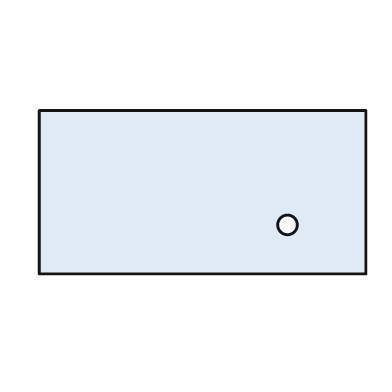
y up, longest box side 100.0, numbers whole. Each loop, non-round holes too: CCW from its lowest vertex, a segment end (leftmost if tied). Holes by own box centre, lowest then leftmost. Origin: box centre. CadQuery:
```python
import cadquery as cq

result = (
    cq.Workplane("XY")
    .moveTo(-50.0, -25.0)
    .lineTo(50.0, -25.0)
    .lineTo(50.0, 25.0)
    .lineTo(-50.0, 25.0)
    .close()
    .moveTo(26.0, -10.0)
    .circle(3.0)
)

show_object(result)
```